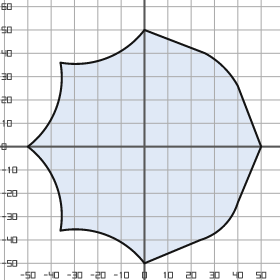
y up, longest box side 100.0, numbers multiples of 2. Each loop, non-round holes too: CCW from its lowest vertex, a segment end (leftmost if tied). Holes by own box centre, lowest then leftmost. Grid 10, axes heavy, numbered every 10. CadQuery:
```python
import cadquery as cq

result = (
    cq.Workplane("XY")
    .moveTo(0.0, -50.0)
    .lineTo(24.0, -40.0)
    .threePointArc((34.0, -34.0), (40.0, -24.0))
    .lineTo(50.0, 0.0)
    .lineTo(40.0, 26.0)
    .threePointArc((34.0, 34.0), (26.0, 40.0))
    .lineTo(0.0, 50.0)
    .threePointArc((-16.0, 38.0), (-36.0, 36.0))
    .threePointArc((-38.0, 16.0), (-50.0, 0.0))
    .threePointArc((-38.0, -16.0), (-36.0, -36.0))
    .threePointArc((-16.0, -38.0), (0.0, -50.0))
    .close()
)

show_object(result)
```